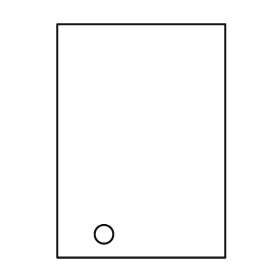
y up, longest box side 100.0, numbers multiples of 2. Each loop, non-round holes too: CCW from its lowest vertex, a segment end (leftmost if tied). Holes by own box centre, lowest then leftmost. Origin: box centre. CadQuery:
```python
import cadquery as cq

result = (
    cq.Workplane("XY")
    .moveTo(-36.0, -50.0)
    .lineTo(36.0, -50.0)
    .lineTo(36.0, 50.0)
    .lineTo(-36.0, 50.0)
    .close()
    .moveTo(-16.0, -40.0)
    .circle(4.0)
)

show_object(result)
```